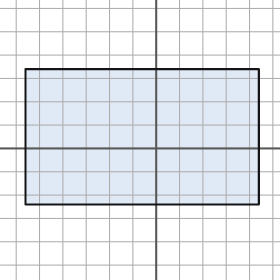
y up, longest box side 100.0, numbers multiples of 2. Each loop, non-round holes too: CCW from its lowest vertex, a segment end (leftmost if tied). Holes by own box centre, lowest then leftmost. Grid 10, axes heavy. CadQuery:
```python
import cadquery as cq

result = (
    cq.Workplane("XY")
    .moveTo(-56.0, -24.0)
    .lineTo(44.0, -24.0)
    .lineTo(44.0, 34.0)
    .lineTo(-56.0, 34.0)
    .close()
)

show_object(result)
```